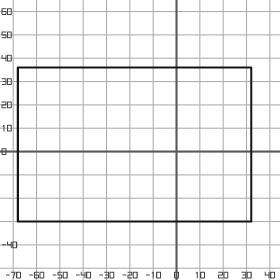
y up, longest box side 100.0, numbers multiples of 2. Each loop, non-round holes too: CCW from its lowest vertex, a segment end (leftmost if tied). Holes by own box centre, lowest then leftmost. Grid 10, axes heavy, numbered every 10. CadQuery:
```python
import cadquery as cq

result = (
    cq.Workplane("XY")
    .moveTo(-68.0, -30.0)
    .lineTo(32.0, -30.0)
    .lineTo(32.0, 36.0)
    .lineTo(-68.0, 36.0)
    .close()
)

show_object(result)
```